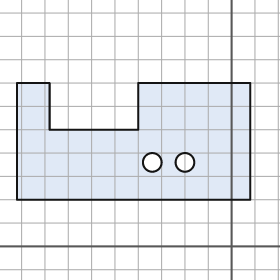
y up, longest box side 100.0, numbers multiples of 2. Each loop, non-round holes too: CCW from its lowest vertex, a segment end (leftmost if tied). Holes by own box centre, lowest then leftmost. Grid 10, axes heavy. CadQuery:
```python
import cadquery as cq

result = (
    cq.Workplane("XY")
    .moveTo(-92.0, 20.0)
    .lineTo(8.0, 20.0)
    .lineTo(8.0, 70.0)
    .lineTo(-40.0, 70.0)
    .lineTo(-40.0, 50.0)
    .lineTo(-78.0, 50.0)
    .lineTo(-78.0, 70.0)
    .lineTo(-92.0, 70.0)
    .close()
    .moveTo(-34.0, 36.0)
    .circle(4.0)
    .moveTo(-20.0, 36.0)
    .circle(4.0)
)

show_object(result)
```